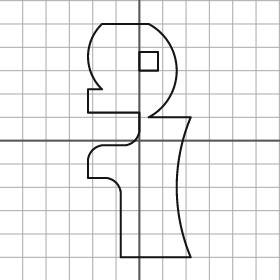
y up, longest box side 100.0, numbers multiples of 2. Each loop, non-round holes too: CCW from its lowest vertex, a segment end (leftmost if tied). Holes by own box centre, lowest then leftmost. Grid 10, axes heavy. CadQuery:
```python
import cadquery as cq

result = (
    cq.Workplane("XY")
    .moveTo(-8.0, -50.0)
    .lineTo(22.0, -50.0)
    .threePointArc((16.0, -20.0), (22.0, 10.0))
    .lineTo(4.0, 10.0)
    .threePointArc((16.0, 30.0), (4.0, 50.0))
    .lineTo(-16.0, 50.0)
    .threePointArc((-22.0, 36.0), (-16.0, 22.0))
    .lineTo(-22.0, 22.0)
    .lineTo(-22.0, 12.0)
    .lineTo(0.0, 12.0)
    .lineTo(0.0, 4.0)
    .threePointArc((-2.0, 0.0), (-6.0, -2.0))
    .lineTo(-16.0, -2.0)
    .threePointArc((-20.0, -4.0), (-22.0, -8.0))
    .lineTo(-22.0, -16.0)
    .lineTo(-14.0, -16.0)
    .threePointArc((-10.0, -18.0), (-8.0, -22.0))
    .close()
    .moveTo(0.0, 30.0)
    .lineTo(8.0, 30.0)
    .lineTo(8.0, 38.0)
    .lineTo(0.0, 38.0)
    .close()
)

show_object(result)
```